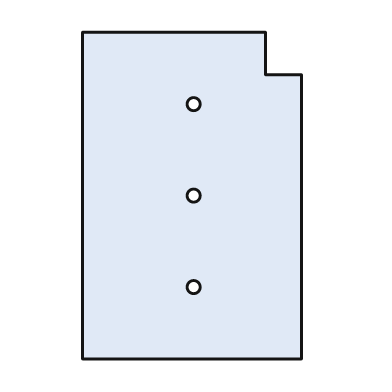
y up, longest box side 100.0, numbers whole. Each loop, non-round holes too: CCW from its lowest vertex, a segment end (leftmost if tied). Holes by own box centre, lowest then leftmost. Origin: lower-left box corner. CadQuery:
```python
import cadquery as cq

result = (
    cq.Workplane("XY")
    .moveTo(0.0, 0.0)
    .lineTo(67.0, 0.0)
    .lineTo(67.0, 87.0)
    .lineTo(56.0, 87.0)
    .lineTo(56.0, 100.0)
    .lineTo(0.0, 100.0)
    .close()
    .moveTo(34.0, 22.0)
    .circle(2.0)
    .moveTo(34.0, 50.0)
    .circle(2.0)
    .moveTo(34.0, 78.0)
    .circle(2.0)
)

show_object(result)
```